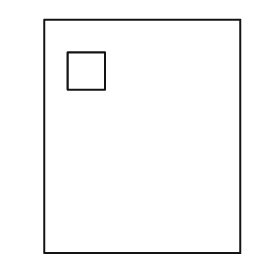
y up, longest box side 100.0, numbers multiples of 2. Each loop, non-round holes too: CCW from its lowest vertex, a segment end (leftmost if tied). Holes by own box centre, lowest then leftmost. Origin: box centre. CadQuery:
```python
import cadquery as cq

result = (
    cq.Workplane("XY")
    .moveTo(-42.0, -50.0)
    .lineTo(42.0, -50.0)
    .lineTo(42.0, 50.0)
    .lineTo(-42.0, 50.0)
    .close()
    .moveTo(-32.0, 20.0)
    .lineTo(-16.0, 20.0)
    .lineTo(-16.0, 36.0)
    .lineTo(-32.0, 36.0)
    .close()
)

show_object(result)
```